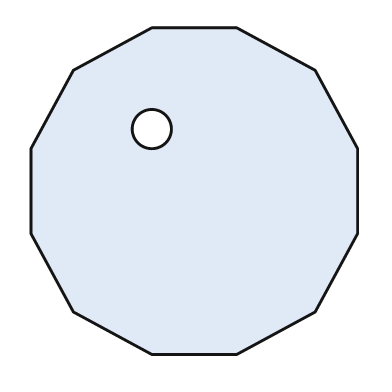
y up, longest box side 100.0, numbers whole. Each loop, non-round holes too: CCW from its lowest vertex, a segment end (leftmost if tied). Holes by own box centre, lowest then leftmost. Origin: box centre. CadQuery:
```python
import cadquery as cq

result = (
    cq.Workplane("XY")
    .moveTo(-13.0, -50.0)
    .lineTo(13.0, -50.0)
    .lineTo(37.0, -37.0)
    .lineTo(50.0, -13.0)
    .lineTo(50.0, 13.0)
    .lineTo(37.0, 37.0)
    .lineTo(13.0, 50.0)
    .lineTo(-13.0, 50.0)
    .lineTo(-37.0, 37.0)
    .lineTo(-50.0, 13.0)
    .lineTo(-50.0, -13.0)
    .lineTo(-37.0, -37.0)
    .close()
    .moveTo(-13.0, 19.0)
    .circle(6.0)
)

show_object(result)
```